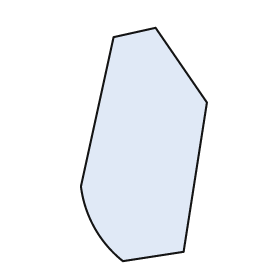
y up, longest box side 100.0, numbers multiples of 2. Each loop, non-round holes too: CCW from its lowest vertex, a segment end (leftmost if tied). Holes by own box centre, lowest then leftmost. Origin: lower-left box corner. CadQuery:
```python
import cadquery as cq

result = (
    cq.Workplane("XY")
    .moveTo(18.0, 0.0)
    .lineTo(44.0, 4.0)
    .lineTo(54.0, 68.0)
    .lineTo(32.0, 100.0)
    .lineTo(14.0, 96.0)
    .lineTo(0.0, 32.0)
    .threePointArc((6.0, 14.0), (18.0, 0.0))
    .close()
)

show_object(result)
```